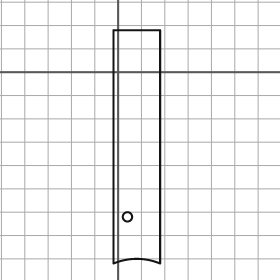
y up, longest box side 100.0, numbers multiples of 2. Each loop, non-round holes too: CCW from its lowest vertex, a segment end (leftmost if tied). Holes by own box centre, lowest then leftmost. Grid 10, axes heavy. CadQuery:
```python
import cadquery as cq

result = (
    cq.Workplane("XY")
    .moveTo(-2.0, -82.0)
    .threePointArc((8.0, -80.0), (18.0, -82.0))
    .lineTo(18.0, 18.0)
    .lineTo(-2.0, 18.0)
    .close()
    .moveTo(4.0, -62.0)
    .circle(2.0)
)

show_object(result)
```